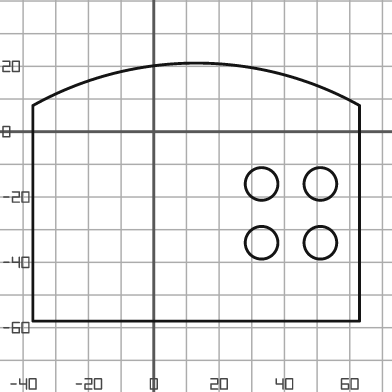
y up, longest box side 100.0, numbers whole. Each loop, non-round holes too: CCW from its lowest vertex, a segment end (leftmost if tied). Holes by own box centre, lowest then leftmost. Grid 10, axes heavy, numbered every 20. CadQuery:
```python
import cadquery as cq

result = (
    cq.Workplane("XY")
    .moveTo(-37.0, -58.0)
    .lineTo(63.0, -58.0)
    .lineTo(63.0, 8.0)
    .threePointArc((13.0, 21.0), (-37.0, 8.0))
    .close()
    .moveTo(33.0, -34.0)
    .circle(5.0)
    .moveTo(51.0, -34.0)
    .circle(5.0)
    .moveTo(33.0, -16.0)
    .circle(5.0)
    .moveTo(51.0, -16.0)
    .circle(5.0)
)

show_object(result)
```